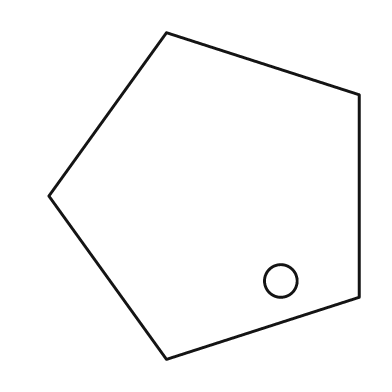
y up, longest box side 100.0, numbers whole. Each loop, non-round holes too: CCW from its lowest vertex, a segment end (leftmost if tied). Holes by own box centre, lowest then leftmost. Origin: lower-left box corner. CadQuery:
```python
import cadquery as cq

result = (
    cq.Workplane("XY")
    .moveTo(36.0, 0.0)
    .lineTo(95.0, 19.0)
    .lineTo(95.0, 81.0)
    .lineTo(36.0, 100.0)
    .lineTo(0.0, 50.0)
    .close()
    .moveTo(71.0, 24.0)
    .circle(5.0)
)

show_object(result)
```